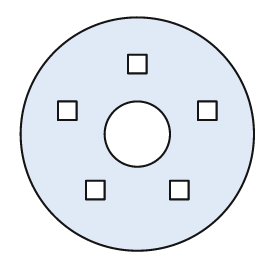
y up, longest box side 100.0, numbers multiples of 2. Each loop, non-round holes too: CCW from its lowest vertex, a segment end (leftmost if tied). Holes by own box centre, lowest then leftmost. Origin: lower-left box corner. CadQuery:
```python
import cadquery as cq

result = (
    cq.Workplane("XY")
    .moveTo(50.0, 50.0)
    .circle(50.0)
    .moveTo(28.0, 22.0)
    .lineTo(36.0, 22.0)
    .lineTo(36.0, 30.0)
    .lineTo(28.0, 30.0)
    .close()
    .moveTo(64.0, 22.0)
    .lineTo(72.0, 22.0)
    .lineTo(72.0, 30.0)
    .lineTo(64.0, 30.0)
    .close()
    .moveTo(50.0, 50.0)
    .circle(14.0)
    .moveTo(16.0, 56.0)
    .lineTo(24.0, 56.0)
    .lineTo(24.0, 64.0)
    .lineTo(16.0, 64.0)
    .close()
    .moveTo(76.0, 56.0)
    .lineTo(84.0, 56.0)
    .lineTo(84.0, 64.0)
    .lineTo(76.0, 64.0)
    .close()
    .moveTo(46.0, 76.0)
    .lineTo(54.0, 76.0)
    .lineTo(54.0, 84.0)
    .lineTo(46.0, 84.0)
    .close()
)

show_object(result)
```